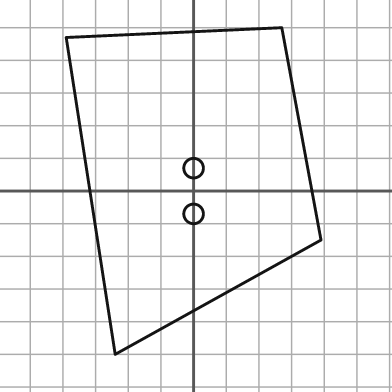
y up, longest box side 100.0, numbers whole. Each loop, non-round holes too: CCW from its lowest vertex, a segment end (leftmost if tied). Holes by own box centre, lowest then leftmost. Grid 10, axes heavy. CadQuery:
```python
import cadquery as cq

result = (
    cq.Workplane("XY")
    .moveTo(-24.0, -50.0)
    .lineTo(39.0, -15.0)
    .lineTo(27.0, 50.0)
    .lineTo(-39.0, 47.0)
    .close()
    .moveTo(0.0, -7.0)
    .circle(3.0)
    .moveTo(0.0, 7.0)
    .circle(3.0)
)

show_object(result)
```